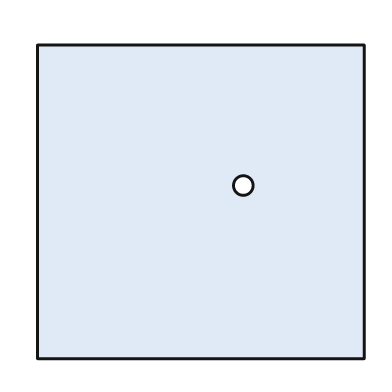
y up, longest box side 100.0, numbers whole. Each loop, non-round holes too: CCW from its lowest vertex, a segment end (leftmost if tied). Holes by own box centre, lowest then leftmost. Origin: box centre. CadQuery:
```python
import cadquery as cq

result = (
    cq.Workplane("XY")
    .moveTo(-50.0, -48.0)
    .lineTo(50.0, -48.0)
    .lineTo(50.0, 48.0)
    .lineTo(-50.0, 48.0)
    .close()
    .moveTo(13.0, 5.0)
    .circle(3.0)
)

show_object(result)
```